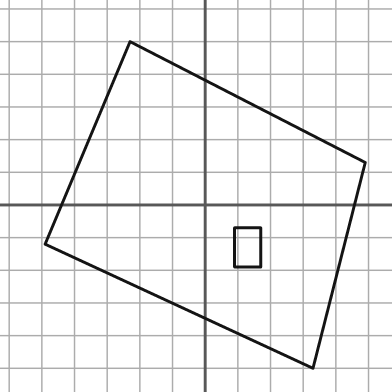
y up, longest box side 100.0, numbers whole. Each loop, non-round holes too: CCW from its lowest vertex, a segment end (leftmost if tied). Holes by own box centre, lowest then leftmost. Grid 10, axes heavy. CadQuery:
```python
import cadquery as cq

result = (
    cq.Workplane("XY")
    .moveTo(33.0, -50.0)
    .lineTo(49.0, 13.0)
    .lineTo(-23.0, 50.0)
    .lineTo(-49.0, -12.0)
    .close()
    .moveTo(9.0, -19.0)
    .lineTo(17.0, -19.0)
    .lineTo(17.0, -7.0)
    .lineTo(9.0, -7.0)
    .close()
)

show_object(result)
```